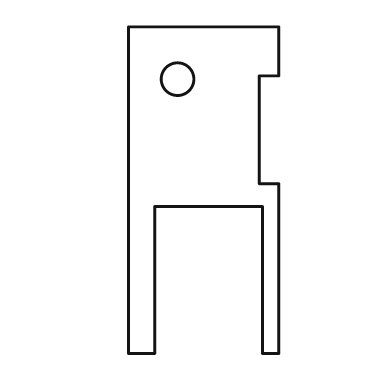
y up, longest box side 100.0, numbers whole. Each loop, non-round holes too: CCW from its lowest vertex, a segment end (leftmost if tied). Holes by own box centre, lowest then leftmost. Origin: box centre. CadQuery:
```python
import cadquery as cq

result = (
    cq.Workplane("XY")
    .moveTo(-23.0, -50.0)
    .lineTo(-15.0, -50.0)
    .lineTo(-15.0, -5.0)
    .lineTo(18.0, -5.0)
    .lineTo(18.0, -50.0)
    .lineTo(23.0, -50.0)
    .lineTo(23.0, 2.0)
    .lineTo(17.0, 2.0)
    .lineTo(17.0, 35.0)
    .lineTo(23.0, 35.0)
    .lineTo(23.0, 50.0)
    .lineTo(-23.0, 50.0)
    .close()
    .moveTo(-8.0, 34.0)
    .circle(5.0)
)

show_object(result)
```